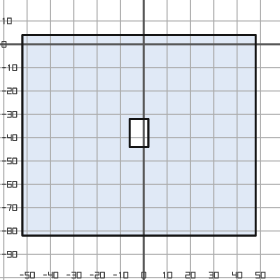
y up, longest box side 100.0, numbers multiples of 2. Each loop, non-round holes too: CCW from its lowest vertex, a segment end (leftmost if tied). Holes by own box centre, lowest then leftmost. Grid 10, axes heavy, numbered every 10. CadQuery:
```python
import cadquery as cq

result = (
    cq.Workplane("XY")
    .moveTo(-52.0, -82.0)
    .lineTo(48.0, -82.0)
    .lineTo(48.0, 4.0)
    .lineTo(-52.0, 4.0)
    .close()
    .moveTo(-6.0, -44.0)
    .lineTo(2.0, -44.0)
    .lineTo(2.0, -32.0)
    .lineTo(-6.0, -32.0)
    .close()
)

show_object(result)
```